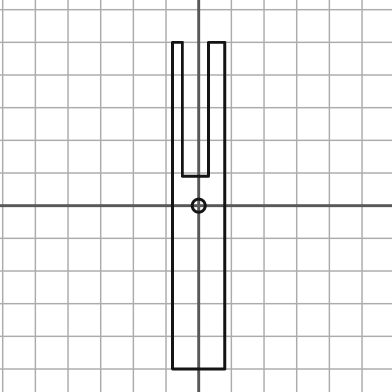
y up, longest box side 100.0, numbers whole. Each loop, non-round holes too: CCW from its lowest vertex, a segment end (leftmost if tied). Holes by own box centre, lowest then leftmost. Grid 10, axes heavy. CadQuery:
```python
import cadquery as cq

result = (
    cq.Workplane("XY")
    .moveTo(-8.0, -50.0)
    .lineTo(8.0, -50.0)
    .lineTo(8.0, 50.0)
    .lineTo(3.0, 50.0)
    .lineTo(3.0, 9.0)
    .lineTo(-5.0, 9.0)
    .lineTo(-5.0, 50.0)
    .lineTo(-8.0, 50.0)
    .close()
    .moveTo(0.0, 0.0)
    .circle(2.0)
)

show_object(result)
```